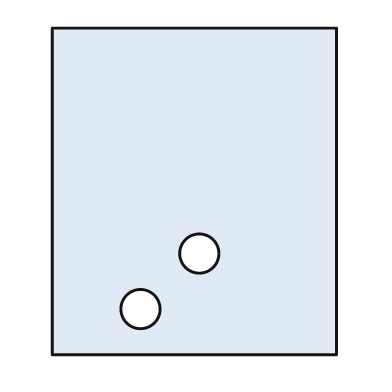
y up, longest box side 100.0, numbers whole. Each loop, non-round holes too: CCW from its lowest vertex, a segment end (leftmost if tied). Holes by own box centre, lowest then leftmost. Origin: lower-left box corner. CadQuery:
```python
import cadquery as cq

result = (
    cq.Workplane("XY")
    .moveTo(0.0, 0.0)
    .lineTo(87.0, 0.0)
    .lineTo(87.0, 100.0)
    .lineTo(0.0, 100.0)
    .close()
    .moveTo(27.0, 14.0)
    .circle(6.0)
    .moveTo(45.0, 31.0)
    .circle(6.0)
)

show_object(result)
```